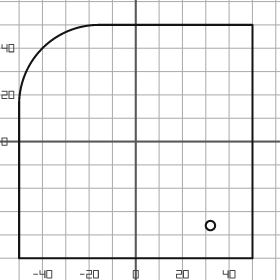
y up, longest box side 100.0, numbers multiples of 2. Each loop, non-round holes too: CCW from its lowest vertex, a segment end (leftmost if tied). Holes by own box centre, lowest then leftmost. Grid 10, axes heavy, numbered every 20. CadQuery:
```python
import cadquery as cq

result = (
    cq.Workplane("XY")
    .moveTo(-50.0, -50.0)
    .lineTo(50.0, -50.0)
    .lineTo(50.0, 50.0)
    .lineTo(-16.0, 50.0)
    .threePointArc((-40.0, 40.0), (-50.0, 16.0))
    .close()
    .moveTo(32.0, -36.0)
    .circle(2.0)
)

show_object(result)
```